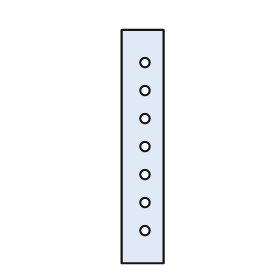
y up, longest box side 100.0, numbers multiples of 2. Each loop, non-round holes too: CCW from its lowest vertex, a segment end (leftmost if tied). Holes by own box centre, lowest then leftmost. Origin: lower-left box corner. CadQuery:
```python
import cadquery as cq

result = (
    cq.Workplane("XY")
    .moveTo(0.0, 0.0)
    .lineTo(18.0, 0.0)
    .lineTo(18.0, 100.0)
    .lineTo(0.0, 100.0)
    .close()
    .moveTo(10.0, 14.0)
    .circle(2.0)
    .moveTo(10.0, 26.0)
    .circle(2.0)
    .moveTo(10.0, 38.0)
    .circle(2.0)
    .moveTo(10.0, 50.0)
    .circle(2.0)
    .moveTo(10.0, 62.0)
    .circle(2.0)
    .moveTo(10.0, 74.0)
    .circle(2.0)
    .moveTo(10.0, 86.0)
    .circle(2.0)
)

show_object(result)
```